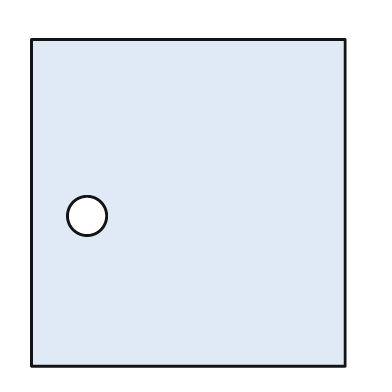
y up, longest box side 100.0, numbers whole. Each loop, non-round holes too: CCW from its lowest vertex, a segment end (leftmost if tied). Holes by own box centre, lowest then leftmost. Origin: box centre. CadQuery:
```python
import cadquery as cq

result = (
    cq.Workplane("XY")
    .moveTo(-48.0, -50.0)
    .lineTo(48.0, -50.0)
    .lineTo(48.0, 50.0)
    .lineTo(-48.0, 50.0)
    .close()
    .moveTo(-31.0, -4.0)
    .circle(6.0)
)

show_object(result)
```